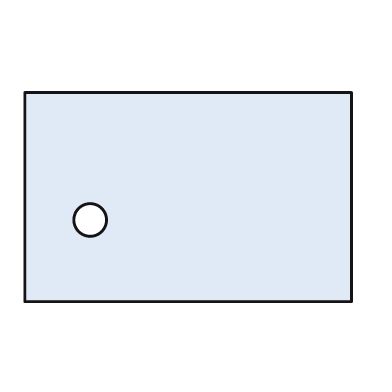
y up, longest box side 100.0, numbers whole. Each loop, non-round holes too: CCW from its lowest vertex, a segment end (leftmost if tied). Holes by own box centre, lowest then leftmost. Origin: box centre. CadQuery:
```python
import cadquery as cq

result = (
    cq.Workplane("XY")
    .moveTo(-50.0, -32.0)
    .lineTo(50.0, -32.0)
    .lineTo(50.0, 32.0)
    .lineTo(-50.0, 32.0)
    .close()
    .moveTo(-30.0, -7.0)
    .circle(5.0)
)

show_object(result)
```